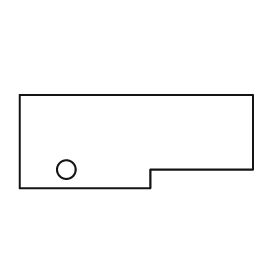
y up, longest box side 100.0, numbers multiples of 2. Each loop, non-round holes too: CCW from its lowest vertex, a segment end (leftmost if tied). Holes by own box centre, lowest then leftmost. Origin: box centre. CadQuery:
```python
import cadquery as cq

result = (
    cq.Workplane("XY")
    .moveTo(-50.0, -20.0)
    .lineTo(6.0, -20.0)
    .lineTo(6.0, -12.0)
    .lineTo(50.0, -12.0)
    .lineTo(50.0, 20.0)
    .lineTo(-50.0, 20.0)
    .close()
    .moveTo(-30.0, -12.0)
    .circle(4.0)
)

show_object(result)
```